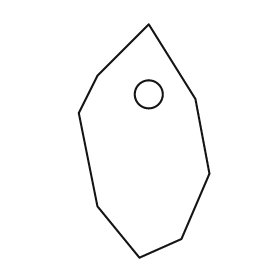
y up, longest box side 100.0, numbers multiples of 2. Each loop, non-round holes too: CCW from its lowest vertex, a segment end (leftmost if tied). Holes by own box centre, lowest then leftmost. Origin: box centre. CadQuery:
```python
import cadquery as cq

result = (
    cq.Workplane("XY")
    .moveTo(-2.0, -50.0)
    .lineTo(16.0, -42.0)
    .lineTo(28.0, -14.0)
    .lineTo(22.0, 18.0)
    .lineTo(2.0, 50.0)
    .lineTo(-20.0, 28.0)
    .lineTo(-28.0, 12.0)
    .lineTo(-20.0, -28.0)
    .close()
    .moveTo(2.0, 20.0)
    .circle(6.0)
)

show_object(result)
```